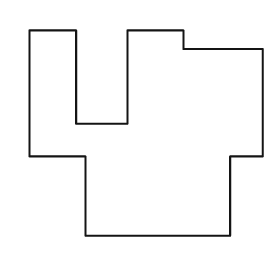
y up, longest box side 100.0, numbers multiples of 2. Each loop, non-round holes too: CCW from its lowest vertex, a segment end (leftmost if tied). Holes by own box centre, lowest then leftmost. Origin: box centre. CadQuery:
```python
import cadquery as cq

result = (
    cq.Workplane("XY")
    .moveTo(-26.0, -44.0)
    .lineTo(36.0, -44.0)
    .lineTo(36.0, -10.0)
    .lineTo(50.0, -10.0)
    .lineTo(50.0, 36.0)
    .lineTo(16.0, 36.0)
    .lineTo(16.0, 44.0)
    .lineTo(-8.0, 44.0)
    .lineTo(-8.0, 4.0)
    .lineTo(-30.0, 4.0)
    .lineTo(-30.0, 44.0)
    .lineTo(-50.0, 44.0)
    .lineTo(-50.0, -10.0)
    .lineTo(-26.0, -10.0)
    .close()
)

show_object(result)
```